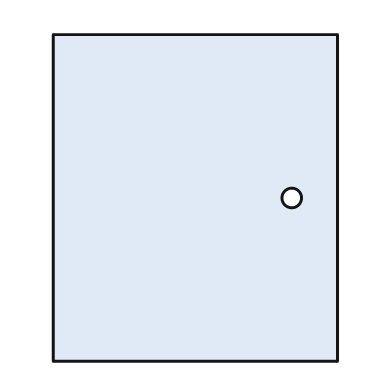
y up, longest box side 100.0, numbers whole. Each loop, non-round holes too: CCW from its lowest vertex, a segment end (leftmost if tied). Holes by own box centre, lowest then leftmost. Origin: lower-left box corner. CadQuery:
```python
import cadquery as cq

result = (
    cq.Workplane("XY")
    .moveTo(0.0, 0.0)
    .lineTo(87.0, 0.0)
    .lineTo(87.0, 100.0)
    .lineTo(0.0, 100.0)
    .close()
    .moveTo(73.0, 50.0)
    .circle(3.0)
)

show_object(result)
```